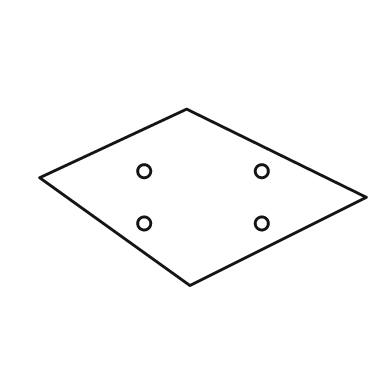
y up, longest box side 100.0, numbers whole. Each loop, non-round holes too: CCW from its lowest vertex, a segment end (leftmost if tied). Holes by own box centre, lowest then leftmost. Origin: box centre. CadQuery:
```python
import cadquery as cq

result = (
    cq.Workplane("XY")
    .moveTo(-4.0, -27.0)
    .lineTo(50.0, 0.0)
    .lineTo(-5.0, 27.0)
    .lineTo(-50.0, 6.0)
    .close()
    .moveTo(-18.0, -8.0)
    .circle(2.0)
    .moveTo(18.0, -8.0)
    .circle(2.0)
    .moveTo(-18.0, 8.0)
    .circle(2.0)
    .moveTo(18.0, 8.0)
    .circle(2.0)
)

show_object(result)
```